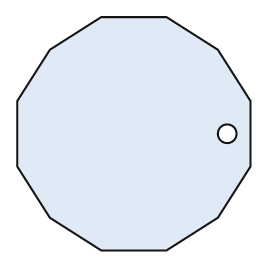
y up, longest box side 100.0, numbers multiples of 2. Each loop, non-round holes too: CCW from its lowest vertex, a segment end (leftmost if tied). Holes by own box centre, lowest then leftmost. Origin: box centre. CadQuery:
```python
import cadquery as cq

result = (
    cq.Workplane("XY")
    .moveTo(-14.0, -50.0)
    .lineTo(14.0, -50.0)
    .lineTo(36.0, -36.0)
    .lineTo(50.0, -14.0)
    .lineTo(50.0, 14.0)
    .lineTo(36.0, 36.0)
    .lineTo(14.0, 50.0)
    .lineTo(-14.0, 50.0)
    .lineTo(-36.0, 36.0)
    .lineTo(-50.0, 14.0)
    .lineTo(-50.0, -14.0)
    .lineTo(-36.0, -36.0)
    .close()
    .moveTo(40.0, 0.0)
    .circle(4.0)
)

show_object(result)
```